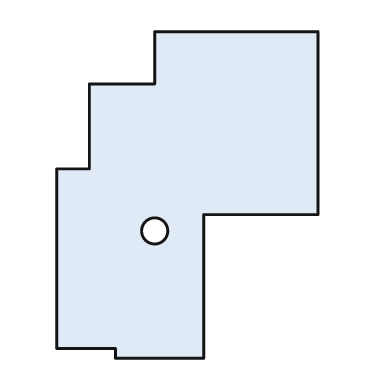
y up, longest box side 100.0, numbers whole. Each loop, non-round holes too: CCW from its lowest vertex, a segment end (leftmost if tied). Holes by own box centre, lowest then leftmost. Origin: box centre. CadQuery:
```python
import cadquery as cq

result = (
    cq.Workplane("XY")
    .moveTo(-22.0, -50.0)
    .lineTo(5.0, -50.0)
    .lineTo(5.0, -6.0)
    .lineTo(40.0, -6.0)
    .lineTo(40.0, 50.0)
    .lineTo(-10.0, 50.0)
    .lineTo(-10.0, 34.0)
    .lineTo(-30.0, 34.0)
    .lineTo(-30.0, 8.0)
    .lineTo(-40.0, 8.0)
    .lineTo(-40.0, -47.0)
    .lineTo(-22.0, -47.0)
    .close()
    .moveTo(-10.0, -11.0)
    .circle(4.0)
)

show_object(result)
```